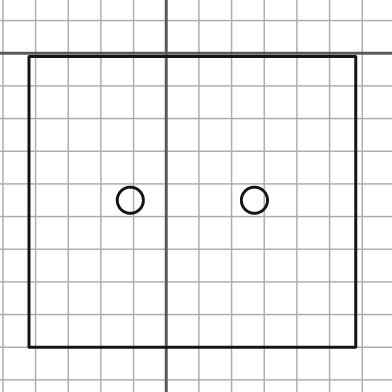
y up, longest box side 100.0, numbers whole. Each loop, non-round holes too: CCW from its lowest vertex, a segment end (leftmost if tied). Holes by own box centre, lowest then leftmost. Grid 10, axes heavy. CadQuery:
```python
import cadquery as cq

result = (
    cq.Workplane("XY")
    .moveTo(-42.0, -90.0)
    .lineTo(58.0, -90.0)
    .lineTo(58.0, -1.0)
    .lineTo(-42.0, -1.0)
    .close()
    .moveTo(-11.0, -45.0)
    .circle(4.0)
    .moveTo(27.0, -45.0)
    .circle(4.0)
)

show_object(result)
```